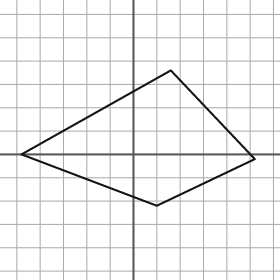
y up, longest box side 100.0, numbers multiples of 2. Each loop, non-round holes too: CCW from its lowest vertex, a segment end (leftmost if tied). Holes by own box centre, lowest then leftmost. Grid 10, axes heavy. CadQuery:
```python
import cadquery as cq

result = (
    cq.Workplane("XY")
    .moveTo(10.0, -22.0)
    .lineTo(52.0, -2.0)
    .lineTo(16.0, 36.0)
    .lineTo(-48.0, 0.0)
    .close()
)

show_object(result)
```